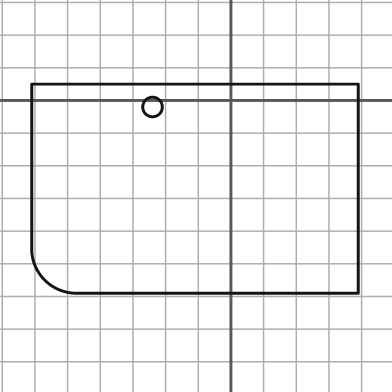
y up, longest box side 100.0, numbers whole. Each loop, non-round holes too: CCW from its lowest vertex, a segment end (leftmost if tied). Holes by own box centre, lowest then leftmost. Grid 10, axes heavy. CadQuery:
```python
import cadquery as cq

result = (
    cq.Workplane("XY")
    .moveTo(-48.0, -59.0)
    .lineTo(39.0, -59.0)
    .lineTo(39.0, 5.0)
    .lineTo(-61.0, 5.0)
    .lineTo(-61.0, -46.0)
    .threePointArc((-57.0, -55.0), (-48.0, -59.0))
    .close()
    .moveTo(-24.0, -2.0)
    .circle(3.0)
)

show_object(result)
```